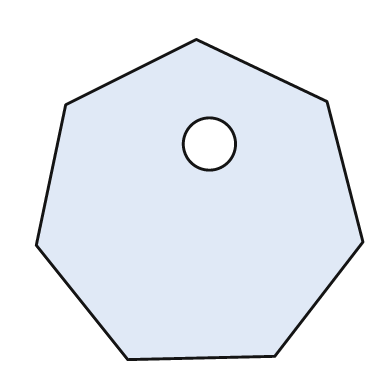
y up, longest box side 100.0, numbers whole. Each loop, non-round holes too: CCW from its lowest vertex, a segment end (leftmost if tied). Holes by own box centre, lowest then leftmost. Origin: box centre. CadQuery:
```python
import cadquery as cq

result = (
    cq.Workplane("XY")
    .moveTo(-22.0, -49.0)
    .lineTo(23.0, -48.0)
    .lineTo(50.0, -13.0)
    .lineTo(39.0, 30.0)
    .lineTo(-1.0, 49.0)
    .lineTo(-41.0, 29.0)
    .lineTo(-50.0, -14.0)
    .close()
    .moveTo(3.0, 17.0)
    .circle(8.0)
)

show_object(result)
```